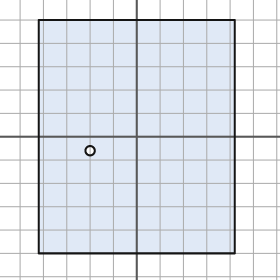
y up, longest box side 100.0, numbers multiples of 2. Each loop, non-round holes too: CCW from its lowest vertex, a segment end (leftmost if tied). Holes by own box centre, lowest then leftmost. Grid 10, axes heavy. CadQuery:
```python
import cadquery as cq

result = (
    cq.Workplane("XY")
    .moveTo(-42.0, -50.0)
    .lineTo(42.0, -50.0)
    .lineTo(42.0, 50.0)
    .lineTo(-42.0, 50.0)
    .close()
    .moveTo(-20.0, -6.0)
    .circle(2.0)
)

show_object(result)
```